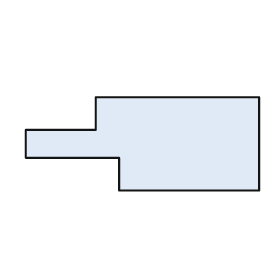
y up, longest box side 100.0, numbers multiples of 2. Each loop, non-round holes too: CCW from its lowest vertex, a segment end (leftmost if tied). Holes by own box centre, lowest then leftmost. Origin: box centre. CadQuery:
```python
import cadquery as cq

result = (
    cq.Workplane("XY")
    .moveTo(-10.0, -20.0)
    .lineTo(50.0, -20.0)
    .lineTo(50.0, 20.0)
    .lineTo(-20.0, 20.0)
    .lineTo(-20.0, 6.0)
    .lineTo(-50.0, 6.0)
    .lineTo(-50.0, -6.0)
    .lineTo(-10.0, -6.0)
    .close()
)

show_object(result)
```